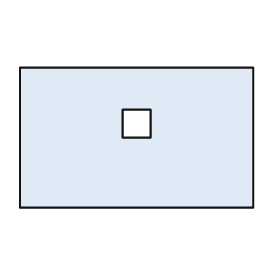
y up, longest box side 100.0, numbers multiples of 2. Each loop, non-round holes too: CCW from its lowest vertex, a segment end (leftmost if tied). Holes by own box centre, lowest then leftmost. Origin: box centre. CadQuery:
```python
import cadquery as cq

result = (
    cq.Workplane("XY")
    .moveTo(-50.0, -30.0)
    .lineTo(50.0, -30.0)
    .lineTo(50.0, 30.0)
    .lineTo(-50.0, 30.0)
    .close()
    .moveTo(-6.0, 0.0)
    .lineTo(6.0, 0.0)
    .lineTo(6.0, 12.0)
    .lineTo(-6.0, 12.0)
    .close()
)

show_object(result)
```